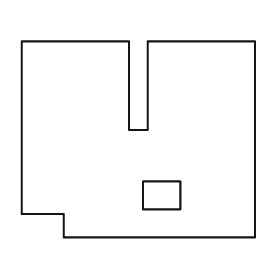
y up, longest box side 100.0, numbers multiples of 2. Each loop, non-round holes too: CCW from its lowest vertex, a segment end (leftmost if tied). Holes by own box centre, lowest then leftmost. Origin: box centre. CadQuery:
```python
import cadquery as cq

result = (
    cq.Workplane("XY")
    .moveTo(-32.0, -42.0)
    .lineTo(50.0, -42.0)
    .lineTo(50.0, 42.0)
    .lineTo(4.0, 42.0)
    .lineTo(4.0, 4.0)
    .lineTo(-4.0, 4.0)
    .lineTo(-4.0, 42.0)
    .lineTo(-50.0, 42.0)
    .lineTo(-50.0, -32.0)
    .lineTo(-32.0, -32.0)
    .close()
    .moveTo(2.0, -30.0)
    .lineTo(18.0, -30.0)
    .lineTo(18.0, -18.0)
    .lineTo(2.0, -18.0)
    .close()
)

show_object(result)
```